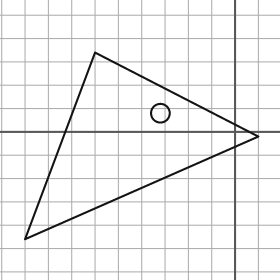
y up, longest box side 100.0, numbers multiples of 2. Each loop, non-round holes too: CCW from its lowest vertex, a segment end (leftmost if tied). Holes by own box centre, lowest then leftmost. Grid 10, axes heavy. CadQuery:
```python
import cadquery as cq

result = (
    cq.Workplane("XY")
    .moveTo(-90.0, -46.0)
    .lineTo(10.0, -2.0)
    .lineTo(-60.0, 34.0)
    .close()
    .moveTo(-32.0, 8.0)
    .circle(4.0)
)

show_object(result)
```